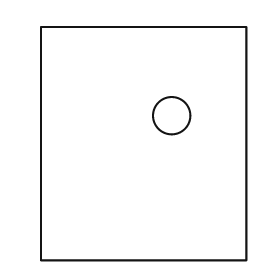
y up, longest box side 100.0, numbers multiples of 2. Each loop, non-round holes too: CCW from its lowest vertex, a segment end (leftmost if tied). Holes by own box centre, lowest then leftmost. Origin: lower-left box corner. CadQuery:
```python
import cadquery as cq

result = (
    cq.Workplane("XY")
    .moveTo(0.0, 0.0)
    .lineTo(88.0, 0.0)
    .lineTo(88.0, 100.0)
    .lineTo(0.0, 100.0)
    .close()
    .moveTo(56.0, 62.0)
    .circle(8.0)
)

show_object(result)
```